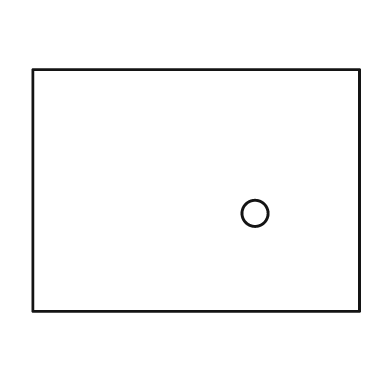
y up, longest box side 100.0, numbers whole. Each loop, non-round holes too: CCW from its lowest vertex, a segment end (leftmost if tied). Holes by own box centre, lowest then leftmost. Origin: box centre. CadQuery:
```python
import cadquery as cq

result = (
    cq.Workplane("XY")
    .moveTo(-50.0, -37.0)
    .lineTo(50.0, -37.0)
    .lineTo(50.0, 37.0)
    .lineTo(-50.0, 37.0)
    .close()
    .moveTo(18.0, -7.0)
    .circle(4.0)
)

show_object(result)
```